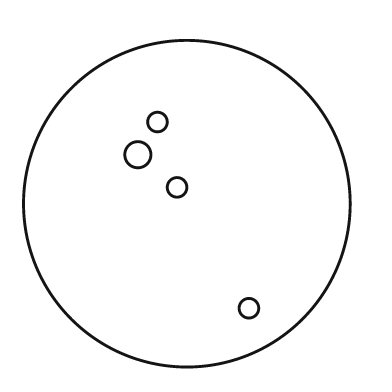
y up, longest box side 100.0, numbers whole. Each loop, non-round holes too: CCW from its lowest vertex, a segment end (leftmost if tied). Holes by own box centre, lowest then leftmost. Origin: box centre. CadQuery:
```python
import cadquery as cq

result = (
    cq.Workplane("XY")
    .moveTo(0.0, 0.0)
    .circle(50.0)
    .moveTo(19.0, -32.0)
    .circle(3.0)
    .moveTo(-3.0, 5.0)
    .circle(3.0)
    .moveTo(-15.0, 15.0)
    .circle(4.0)
    .moveTo(-9.0, 25.0)
    .circle(3.0)
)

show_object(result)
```